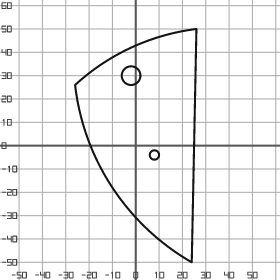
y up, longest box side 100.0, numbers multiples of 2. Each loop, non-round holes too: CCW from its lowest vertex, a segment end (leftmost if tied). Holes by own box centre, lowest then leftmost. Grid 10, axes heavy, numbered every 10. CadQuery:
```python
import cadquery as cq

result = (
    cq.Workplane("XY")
    .moveTo(24.0, -50.0)
    .lineTo(26.0, 50.0)
    .threePointArc((-2.0, 42.0), (-26.0, 26.0))
    .threePointArc((-10.0, -18.0), (24.0, -50.0))
    .close()
    .moveTo(8.0, -4.0)
    .circle(2.0)
    .moveTo(-2.0, 30.0)
    .circle(4.0)
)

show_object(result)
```